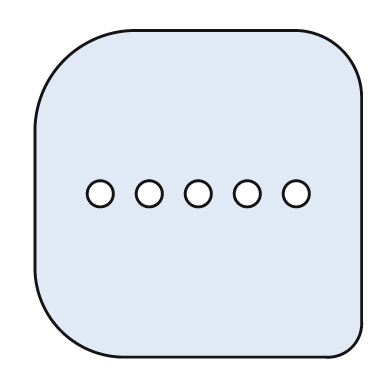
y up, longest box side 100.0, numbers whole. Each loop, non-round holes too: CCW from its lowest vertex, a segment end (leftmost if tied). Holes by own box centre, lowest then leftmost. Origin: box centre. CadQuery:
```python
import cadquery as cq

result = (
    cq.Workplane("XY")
    .moveTo(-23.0, -50.0)
    .lineTo(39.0, -50.0)
    .threePointArc((47.0, -47.0), (50.0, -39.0))
    .lineTo(50.0, 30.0)
    .threePointArc((44.0, 44.0), (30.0, 50.0))
    .lineTo(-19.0, 50.0)
    .threePointArc((-41.0, 41.0), (-50.0, 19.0))
    .lineTo(-50.0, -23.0)
    .threePointArc((-42.0, -42.0), (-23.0, -50.0))
    .close()
    .moveTo(-30.0, 0.0)
    .circle(4.0)
    .moveTo(-15.0, 0.0)
    .circle(4.0)
    .moveTo(0.0, 0.0)
    .circle(4.0)
    .moveTo(15.0, 0.0)
    .circle(4.0)
    .moveTo(30.0, 0.0)
    .circle(4.0)
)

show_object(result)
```